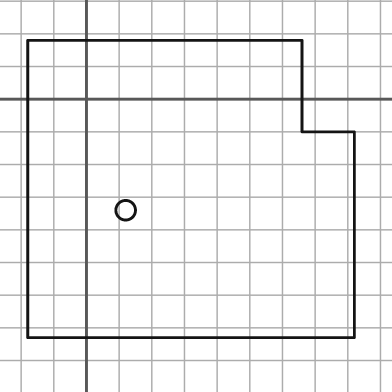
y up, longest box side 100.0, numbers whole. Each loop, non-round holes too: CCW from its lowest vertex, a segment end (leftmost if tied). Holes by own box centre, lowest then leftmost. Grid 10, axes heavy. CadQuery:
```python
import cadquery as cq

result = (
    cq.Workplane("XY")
    .moveTo(-18.0, -73.0)
    .lineTo(82.0, -73.0)
    .lineTo(82.0, -10.0)
    .lineTo(66.0, -10.0)
    .lineTo(66.0, 18.0)
    .lineTo(-18.0, 18.0)
    .close()
    .moveTo(12.0, -34.0)
    .circle(3.0)
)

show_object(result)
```